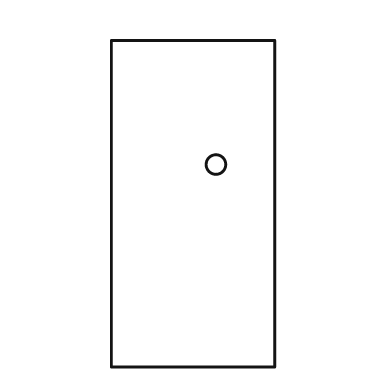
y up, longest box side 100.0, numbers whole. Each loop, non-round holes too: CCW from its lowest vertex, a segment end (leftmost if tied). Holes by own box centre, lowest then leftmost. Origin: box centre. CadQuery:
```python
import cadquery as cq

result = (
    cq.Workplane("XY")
    .moveTo(-25.0, -50.0)
    .lineTo(25.0, -50.0)
    .lineTo(25.0, 50.0)
    .lineTo(-25.0, 50.0)
    .close()
    .moveTo(7.0, 12.0)
    .circle(3.0)
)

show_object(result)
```